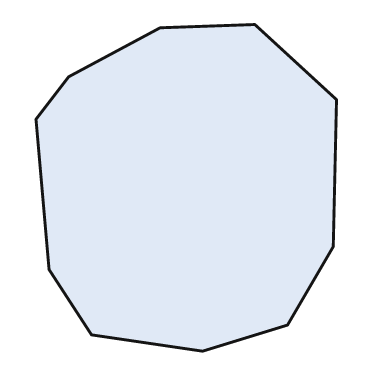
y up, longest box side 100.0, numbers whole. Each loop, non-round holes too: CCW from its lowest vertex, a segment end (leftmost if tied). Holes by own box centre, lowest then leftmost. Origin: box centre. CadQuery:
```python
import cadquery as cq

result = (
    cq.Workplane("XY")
    .moveTo(5.0, -50.0)
    .lineTo(31.0, -42.0)
    .lineTo(45.0, -18.0)
    .lineTo(46.0, 27.0)
    .lineTo(21.0, 50.0)
    .lineTo(-8.0, 49.0)
    .lineTo(-36.0, 34.0)
    .lineTo(-46.0, 21.0)
    .lineTo(-42.0, -25.0)
    .lineTo(-29.0, -45.0)
    .close()
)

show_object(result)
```